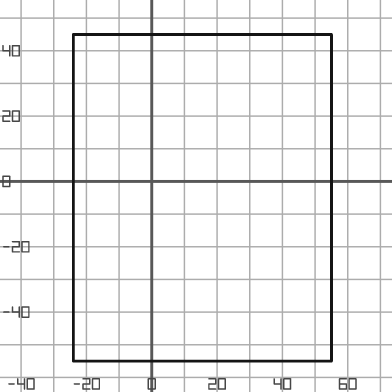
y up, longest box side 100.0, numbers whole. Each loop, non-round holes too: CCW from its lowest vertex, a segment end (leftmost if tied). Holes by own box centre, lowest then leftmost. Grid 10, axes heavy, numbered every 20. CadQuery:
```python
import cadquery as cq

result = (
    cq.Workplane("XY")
    .moveTo(-24.0, -55.0)
    .lineTo(55.0, -55.0)
    .lineTo(55.0, 45.0)
    .lineTo(-24.0, 45.0)
    .close()
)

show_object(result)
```